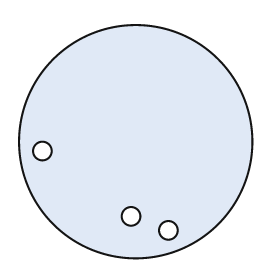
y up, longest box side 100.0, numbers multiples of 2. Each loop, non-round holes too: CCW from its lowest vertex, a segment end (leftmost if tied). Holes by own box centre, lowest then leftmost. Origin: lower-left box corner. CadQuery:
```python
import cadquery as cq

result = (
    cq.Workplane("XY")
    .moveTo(50.0, 50.0)
    .circle(50.0)
    .moveTo(64.0, 12.0)
    .circle(4.0)
    .moveTo(48.0, 18.0)
    .circle(4.0)
    .moveTo(10.0, 46.0)
    .circle(4.0)
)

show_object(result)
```